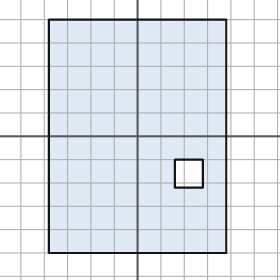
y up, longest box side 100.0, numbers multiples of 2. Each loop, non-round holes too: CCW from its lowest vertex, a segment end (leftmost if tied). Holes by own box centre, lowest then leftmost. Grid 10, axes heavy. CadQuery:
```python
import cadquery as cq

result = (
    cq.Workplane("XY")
    .moveTo(-38.0, -50.0)
    .lineTo(38.0, -50.0)
    .lineTo(38.0, 50.0)
    .lineTo(-38.0, 50.0)
    .close()
    .moveTo(16.0, -22.0)
    .lineTo(28.0, -22.0)
    .lineTo(28.0, -10.0)
    .lineTo(16.0, -10.0)
    .close()
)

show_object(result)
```